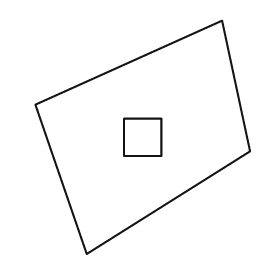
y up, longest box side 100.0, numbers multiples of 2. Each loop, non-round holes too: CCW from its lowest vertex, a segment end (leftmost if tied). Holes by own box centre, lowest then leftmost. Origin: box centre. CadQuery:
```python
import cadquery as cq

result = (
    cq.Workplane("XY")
    .moveTo(-24.0, -50.0)
    .lineTo(46.0, -6.0)
    .lineTo(34.0, 50.0)
    .lineTo(-46.0, 14.0)
    .close()
    .moveTo(-8.0, -8.0)
    .lineTo(8.0, -8.0)
    .lineTo(8.0, 8.0)
    .lineTo(-8.0, 8.0)
    .close()
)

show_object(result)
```